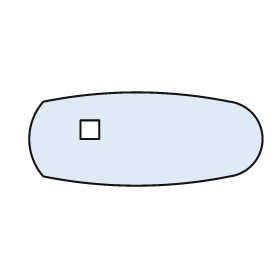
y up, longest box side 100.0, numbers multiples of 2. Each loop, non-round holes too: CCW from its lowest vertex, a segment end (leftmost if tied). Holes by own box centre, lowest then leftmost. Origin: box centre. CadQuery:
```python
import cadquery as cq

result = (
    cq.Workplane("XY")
    .moveTo(-44.0, -16.0)
    .threePointArc((-4.0, -20.0), (36.0, -16.0))
    .threePointArc((50.0, 0.0), (36.0, 16.0))
    .threePointArc((-4.0, 20.0), (-44.0, 16.0))
    .threePointArc((-50.0, 0.0), (-44.0, -16.0))
    .close()
    .moveTo(-28.0, 0.0)
    .lineTo(-20.0, 0.0)
    .lineTo(-20.0, 8.0)
    .lineTo(-28.0, 8.0)
    .close()
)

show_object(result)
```